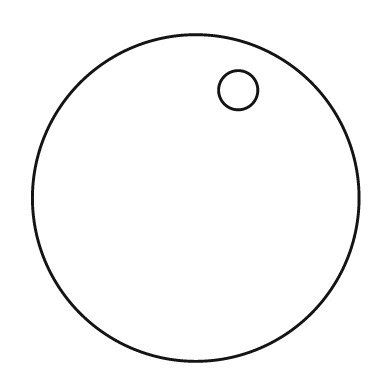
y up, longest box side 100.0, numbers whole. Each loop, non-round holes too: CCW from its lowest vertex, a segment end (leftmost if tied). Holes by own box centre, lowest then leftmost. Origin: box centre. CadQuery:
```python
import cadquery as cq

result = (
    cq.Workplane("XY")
    .moveTo(0.0, 0.0)
    .circle(50.0)
    .moveTo(13.0, 33.0)
    .circle(6.0)
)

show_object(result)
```